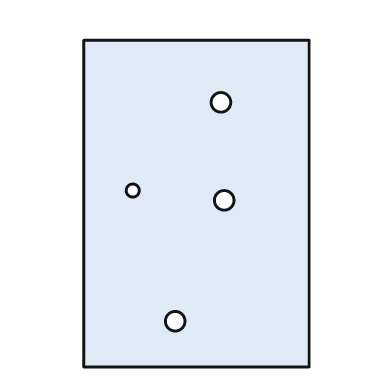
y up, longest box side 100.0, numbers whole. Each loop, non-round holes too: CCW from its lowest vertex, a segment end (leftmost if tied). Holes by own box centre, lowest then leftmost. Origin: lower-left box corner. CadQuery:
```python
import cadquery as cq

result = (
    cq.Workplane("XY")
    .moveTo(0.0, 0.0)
    .lineTo(69.0, 0.0)
    .lineTo(69.0, 100.0)
    .lineTo(0.0, 100.0)
    .close()
    .moveTo(28.0, 14.0)
    .circle(3.0)
    .moveTo(43.0, 51.0)
    .circle(3.0)
    .moveTo(15.0, 54.0)
    .circle(2.0)
    .moveTo(42.0, 81.0)
    .circle(3.0)
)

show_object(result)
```